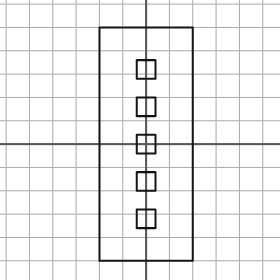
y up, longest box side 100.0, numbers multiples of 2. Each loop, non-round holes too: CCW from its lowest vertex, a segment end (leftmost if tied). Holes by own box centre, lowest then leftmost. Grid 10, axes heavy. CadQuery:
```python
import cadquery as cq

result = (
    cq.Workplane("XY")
    .moveTo(-20.0, -50.0)
    .lineTo(20.0, -50.0)
    .lineTo(20.0, 50.0)
    .lineTo(-20.0, 50.0)
    .close()
    .moveTo(-4.0, -36.0)
    .lineTo(4.0, -36.0)
    .lineTo(4.0, -28.0)
    .lineTo(-4.0, -28.0)
    .close()
    .moveTo(-4.0, -20.0)
    .lineTo(4.0, -20.0)
    .lineTo(4.0, -12.0)
    .lineTo(-4.0, -12.0)
    .close()
    .moveTo(-4.0, -4.0)
    .lineTo(4.0, -4.0)
    .lineTo(4.0, 4.0)
    .lineTo(-4.0, 4.0)
    .close()
    .moveTo(-4.0, 12.0)
    .lineTo(4.0, 12.0)
    .lineTo(4.0, 20.0)
    .lineTo(-4.0, 20.0)
    .close()
    .moveTo(-4.0, 28.0)
    .lineTo(4.0, 28.0)
    .lineTo(4.0, 36.0)
    .lineTo(-4.0, 36.0)
    .close()
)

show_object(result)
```